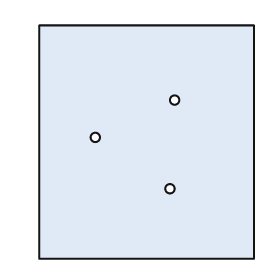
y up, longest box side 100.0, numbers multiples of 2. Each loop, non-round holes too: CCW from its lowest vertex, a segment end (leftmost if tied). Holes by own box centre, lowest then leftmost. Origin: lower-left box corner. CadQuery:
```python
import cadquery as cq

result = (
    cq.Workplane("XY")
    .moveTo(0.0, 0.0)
    .lineTo(92.0, 0.0)
    .lineTo(92.0, 100.0)
    .lineTo(0.0, 100.0)
    .close()
    .moveTo(56.0, 30.0)
    .circle(2.0)
    .moveTo(24.0, 52.0)
    .circle(2.0)
    .moveTo(58.0, 68.0)
    .circle(2.0)
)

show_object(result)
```